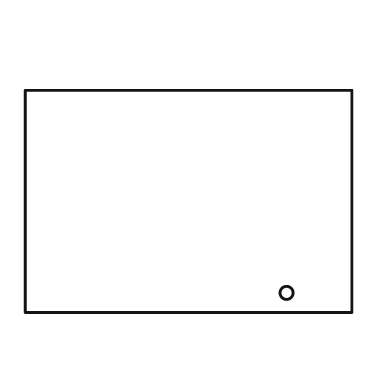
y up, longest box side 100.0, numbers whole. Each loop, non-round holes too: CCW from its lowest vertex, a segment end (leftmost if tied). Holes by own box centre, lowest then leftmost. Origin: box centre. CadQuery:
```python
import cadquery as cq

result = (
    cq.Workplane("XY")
    .moveTo(-50.0, -34.0)
    .lineTo(50.0, -34.0)
    .lineTo(50.0, 34.0)
    .lineTo(-50.0, 34.0)
    .close()
    .moveTo(30.0, -28.0)
    .circle(2.0)
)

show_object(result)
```